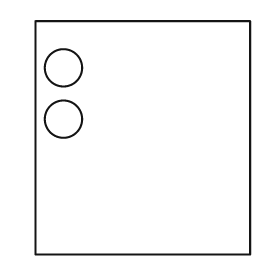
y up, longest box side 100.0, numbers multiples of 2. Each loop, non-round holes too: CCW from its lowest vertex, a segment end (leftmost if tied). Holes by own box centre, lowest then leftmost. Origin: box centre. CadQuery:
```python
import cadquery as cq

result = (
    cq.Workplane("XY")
    .moveTo(-46.0, -50.0)
    .lineTo(46.0, -50.0)
    .lineTo(46.0, 50.0)
    .lineTo(-46.0, 50.0)
    .close()
    .moveTo(-34.0, 8.0)
    .circle(8.0)
    .moveTo(-34.0, 30.0)
    .circle(8.0)
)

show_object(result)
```